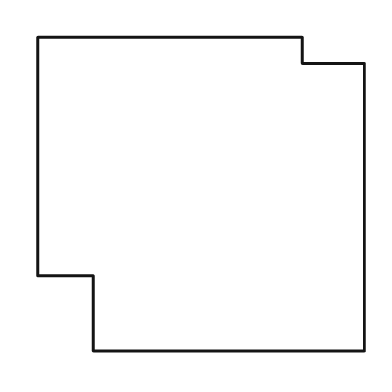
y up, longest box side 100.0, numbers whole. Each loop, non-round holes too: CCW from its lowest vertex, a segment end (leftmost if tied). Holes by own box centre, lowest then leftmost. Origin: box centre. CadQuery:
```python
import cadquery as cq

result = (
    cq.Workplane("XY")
    .moveTo(-33.0, -48.0)
    .lineTo(50.0, -48.0)
    .lineTo(50.0, 40.0)
    .lineTo(31.0, 40.0)
    .lineTo(31.0, 48.0)
    .lineTo(-50.0, 48.0)
    .lineTo(-50.0, -25.0)
    .lineTo(-33.0, -25.0)
    .close()
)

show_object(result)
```